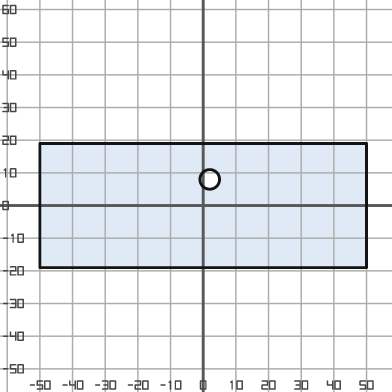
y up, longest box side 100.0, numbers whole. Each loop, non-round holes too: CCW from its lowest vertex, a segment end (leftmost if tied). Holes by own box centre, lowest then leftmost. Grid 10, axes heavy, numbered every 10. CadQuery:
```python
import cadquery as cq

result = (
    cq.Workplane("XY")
    .moveTo(-50.0, -19.0)
    .lineTo(50.0, -19.0)
    .lineTo(50.0, 19.0)
    .lineTo(-50.0, 19.0)
    .close()
    .moveTo(2.0, 8.0)
    .circle(3.0)
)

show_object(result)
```